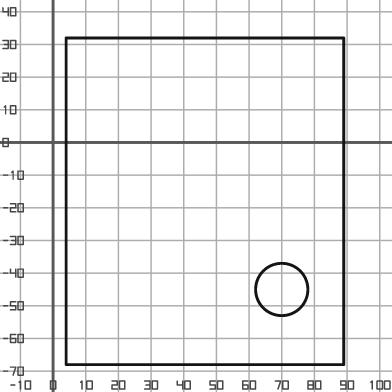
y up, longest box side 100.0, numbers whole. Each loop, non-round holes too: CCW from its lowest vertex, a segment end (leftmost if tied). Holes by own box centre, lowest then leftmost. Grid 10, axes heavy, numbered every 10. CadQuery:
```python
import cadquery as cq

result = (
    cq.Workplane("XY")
    .moveTo(4.0, -68.0)
    .lineTo(89.0, -68.0)
    .lineTo(89.0, 32.0)
    .lineTo(4.0, 32.0)
    .close()
    .moveTo(70.0, -45.0)
    .circle(8.0)
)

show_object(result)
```